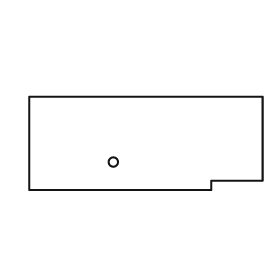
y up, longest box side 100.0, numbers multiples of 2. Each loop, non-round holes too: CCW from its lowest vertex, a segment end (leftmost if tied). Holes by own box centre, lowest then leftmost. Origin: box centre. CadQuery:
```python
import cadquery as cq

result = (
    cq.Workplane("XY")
    .moveTo(-50.0, -20.0)
    .lineTo(28.0, -20.0)
    .lineTo(28.0, -16.0)
    .lineTo(50.0, -16.0)
    .lineTo(50.0, 20.0)
    .lineTo(-50.0, 20.0)
    .close()
    .moveTo(-14.0, -8.0)
    .circle(2.0)
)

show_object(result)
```